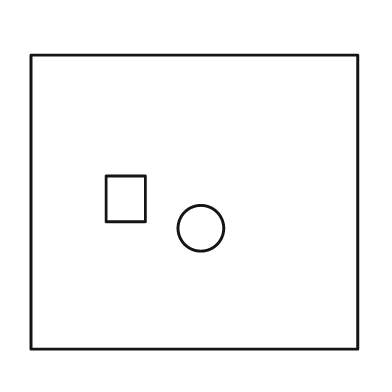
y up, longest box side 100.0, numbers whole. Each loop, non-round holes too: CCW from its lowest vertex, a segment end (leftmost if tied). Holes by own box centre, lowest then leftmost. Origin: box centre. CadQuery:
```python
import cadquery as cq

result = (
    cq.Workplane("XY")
    .moveTo(-50.0, -45.0)
    .lineTo(50.0, -45.0)
    .lineTo(50.0, 45.0)
    .lineTo(-50.0, 45.0)
    .close()
    .moveTo(2.0, -8.0)
    .circle(7.0)
    .moveTo(-27.0, -6.0)
    .lineTo(-15.0, -6.0)
    .lineTo(-15.0, 8.0)
    .lineTo(-27.0, 8.0)
    .close()
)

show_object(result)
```